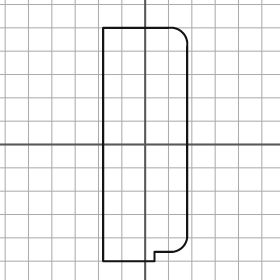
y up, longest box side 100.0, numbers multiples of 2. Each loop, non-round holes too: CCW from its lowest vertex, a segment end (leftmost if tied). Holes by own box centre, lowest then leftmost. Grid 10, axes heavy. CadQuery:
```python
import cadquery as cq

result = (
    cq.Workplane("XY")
    .moveTo(-18.0, -50.0)
    .lineTo(4.0, -50.0)
    .lineTo(4.0, -46.0)
    .lineTo(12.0, -46.0)
    .threePointArc((16.0, -44.0), (18.0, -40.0))
    .lineTo(18.0, 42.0)
    .threePointArc((16.0, 48.0), (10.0, 50.0))
    .lineTo(-18.0, 50.0)
    .close()
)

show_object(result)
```